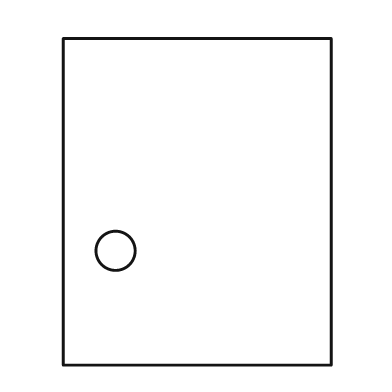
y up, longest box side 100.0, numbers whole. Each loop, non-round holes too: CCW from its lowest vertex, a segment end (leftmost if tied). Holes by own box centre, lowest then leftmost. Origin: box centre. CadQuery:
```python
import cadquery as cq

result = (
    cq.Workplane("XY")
    .moveTo(-41.0, -50.0)
    .lineTo(41.0, -50.0)
    .lineTo(41.0, 50.0)
    .lineTo(-41.0, 50.0)
    .close()
    .moveTo(-25.0, -15.0)
    .circle(6.0)
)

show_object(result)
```